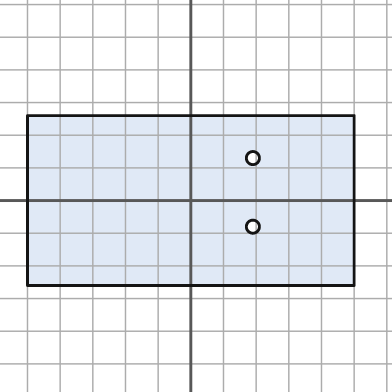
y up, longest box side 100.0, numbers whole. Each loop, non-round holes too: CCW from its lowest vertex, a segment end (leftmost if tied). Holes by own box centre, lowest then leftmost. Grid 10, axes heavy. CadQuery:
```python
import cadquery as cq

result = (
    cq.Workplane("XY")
    .moveTo(-50.0, -26.0)
    .lineTo(50.0, -26.0)
    .lineTo(50.0, 26.0)
    .lineTo(-50.0, 26.0)
    .close()
    .moveTo(19.0, -8.0)
    .circle(2.0)
    .moveTo(19.0, 13.0)
    .circle(2.0)
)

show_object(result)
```